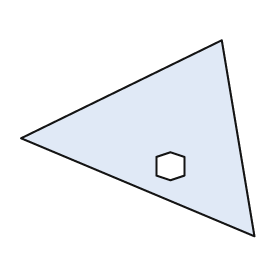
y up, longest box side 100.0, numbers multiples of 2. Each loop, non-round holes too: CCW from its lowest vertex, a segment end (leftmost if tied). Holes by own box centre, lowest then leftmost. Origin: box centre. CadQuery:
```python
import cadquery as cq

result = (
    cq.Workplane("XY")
    .moveTo(50.0, -42.0)
    .lineTo(36.0, 42.0)
    .lineTo(-50.0, 0.0)
    .close()
    .moveTo(14.0, -18.0)
    .lineTo(20.0, -16.0)
    .lineTo(20.0, -8.0)
    .lineTo(14.0, -6.0)
    .lineTo(8.0, -8.0)
    .lineTo(8.0, -16.0)
    .close()
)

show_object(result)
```